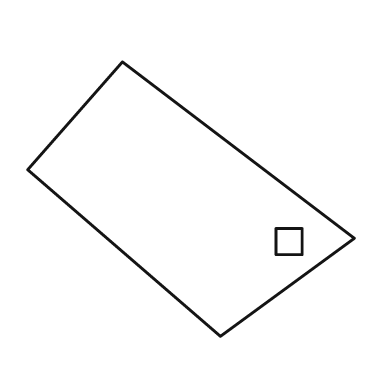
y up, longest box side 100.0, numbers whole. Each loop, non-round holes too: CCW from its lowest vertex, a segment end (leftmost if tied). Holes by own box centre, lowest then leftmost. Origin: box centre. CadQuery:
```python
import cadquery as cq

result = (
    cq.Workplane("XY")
    .moveTo(9.0, -42.0)
    .lineTo(50.0, -12.0)
    .lineTo(-21.0, 42.0)
    .lineTo(-50.0, 9.0)
    .close()
    .moveTo(26.0, -17.0)
    .lineTo(34.0, -17.0)
    .lineTo(34.0, -9.0)
    .lineTo(26.0, -9.0)
    .close()
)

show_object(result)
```